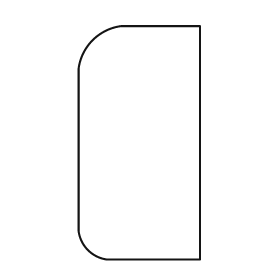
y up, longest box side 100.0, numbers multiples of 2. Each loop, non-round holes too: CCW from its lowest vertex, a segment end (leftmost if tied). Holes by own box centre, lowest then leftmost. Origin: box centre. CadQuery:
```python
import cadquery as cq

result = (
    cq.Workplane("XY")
    .moveTo(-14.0, -50.0)
    .lineTo(26.0, -50.0)
    .lineTo(26.0, 50.0)
    .lineTo(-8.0, 50.0)
    .threePointArc((-20.0, 44.0), (-26.0, 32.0))
    .lineTo(-26.0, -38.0)
    .threePointArc((-22.0, -46.0), (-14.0, -50.0))
    .close()
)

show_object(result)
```